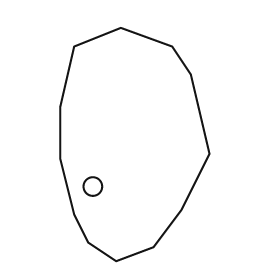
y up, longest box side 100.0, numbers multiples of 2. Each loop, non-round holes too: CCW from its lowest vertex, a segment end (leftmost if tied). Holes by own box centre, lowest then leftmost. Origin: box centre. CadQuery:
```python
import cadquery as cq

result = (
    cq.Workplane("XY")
    .moveTo(-8.0, -50.0)
    .lineTo(8.0, -44.0)
    .lineTo(20.0, -28.0)
    .lineTo(32.0, -4.0)
    .lineTo(24.0, 30.0)
    .lineTo(16.0, 42.0)
    .lineTo(-6.0, 50.0)
    .lineTo(-26.0, 42.0)
    .lineTo(-32.0, 16.0)
    .lineTo(-32.0, -6.0)
    .lineTo(-26.0, -30.0)
    .lineTo(-20.0, -42.0)
    .close()
    .moveTo(-18.0, -18.0)
    .circle(4.0)
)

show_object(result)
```